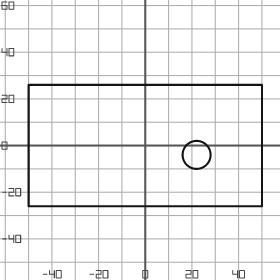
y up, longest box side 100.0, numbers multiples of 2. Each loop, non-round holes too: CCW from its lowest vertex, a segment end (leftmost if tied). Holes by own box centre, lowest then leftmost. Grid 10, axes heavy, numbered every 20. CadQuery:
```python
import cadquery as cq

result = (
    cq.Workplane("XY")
    .moveTo(-50.0, -26.0)
    .lineTo(50.0, -26.0)
    .lineTo(50.0, 26.0)
    .lineTo(-50.0, 26.0)
    .close()
    .moveTo(22.0, -4.0)
    .circle(6.0)
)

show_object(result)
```